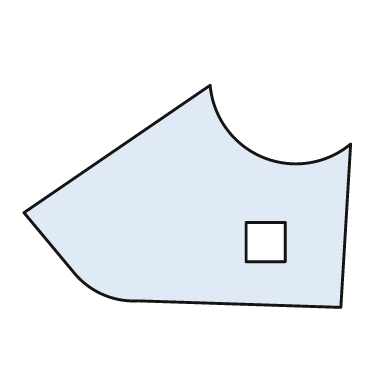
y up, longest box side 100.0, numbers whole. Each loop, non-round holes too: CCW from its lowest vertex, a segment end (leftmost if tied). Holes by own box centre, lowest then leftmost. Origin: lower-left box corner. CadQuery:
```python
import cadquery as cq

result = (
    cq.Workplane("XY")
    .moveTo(97.0, 0.0)
    .lineTo(100.0, 50.0)
    .threePointArc((73.0, 46.0), (57.0, 68.0))
    .lineTo(0.0, 29.0)
    .lineTo(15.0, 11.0)
    .threePointArc((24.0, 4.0), (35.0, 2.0))
    .close()
    .moveTo(68.0, 14.0)
    .lineTo(80.0, 14.0)
    .lineTo(80.0, 26.0)
    .lineTo(68.0, 26.0)
    .close()
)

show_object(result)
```